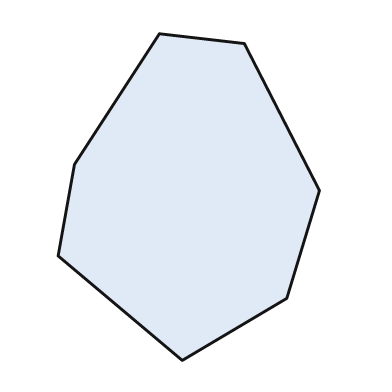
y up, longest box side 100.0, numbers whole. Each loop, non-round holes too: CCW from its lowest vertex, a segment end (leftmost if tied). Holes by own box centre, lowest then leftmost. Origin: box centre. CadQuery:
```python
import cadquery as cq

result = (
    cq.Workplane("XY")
    .moveTo(-2.0, -50.0)
    .lineTo(30.0, -31.0)
    .lineTo(40.0, 2.0)
    .lineTo(17.0, 47.0)
    .lineTo(-9.0, 50.0)
    .lineTo(-35.0, 10.0)
    .lineTo(-40.0, -18.0)
    .close()
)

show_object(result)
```